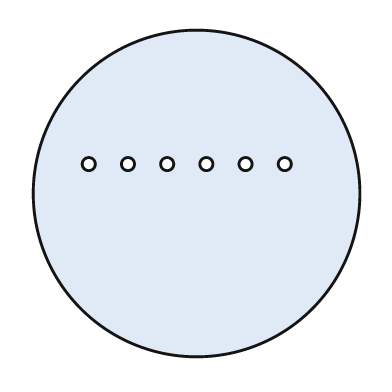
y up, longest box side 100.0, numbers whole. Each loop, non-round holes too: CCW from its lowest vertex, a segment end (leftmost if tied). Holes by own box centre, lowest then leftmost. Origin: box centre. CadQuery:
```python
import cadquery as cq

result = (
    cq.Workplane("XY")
    .moveTo(0.0, 0.0)
    .circle(50.0)
    .moveTo(-33.0, 9.0)
    .circle(2.0)
    .moveTo(-21.0, 9.0)
    .circle(2.0)
    .moveTo(-9.0, 9.0)
    .circle(2.0)
    .moveTo(3.0, 9.0)
    .circle(2.0)
    .moveTo(15.0, 9.0)
    .circle(2.0)
    .moveTo(27.0, 9.0)
    .circle(2.0)
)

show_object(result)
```